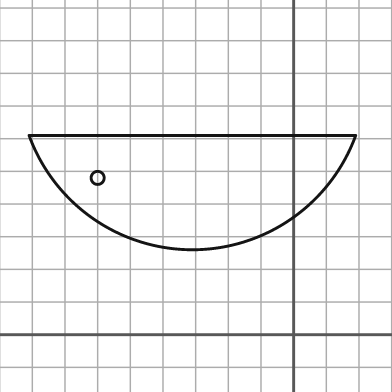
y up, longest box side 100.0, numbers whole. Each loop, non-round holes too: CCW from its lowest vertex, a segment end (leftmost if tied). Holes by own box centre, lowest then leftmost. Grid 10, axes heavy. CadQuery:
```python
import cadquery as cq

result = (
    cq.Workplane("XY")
    .moveTo(-81.0, 61.0)
    .threePointArc((-31.0, 26.0), (19.0, 61.0))
    .close()
    .moveTo(-60.0, 48.0)
    .circle(2.0)
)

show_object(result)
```